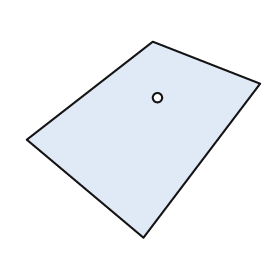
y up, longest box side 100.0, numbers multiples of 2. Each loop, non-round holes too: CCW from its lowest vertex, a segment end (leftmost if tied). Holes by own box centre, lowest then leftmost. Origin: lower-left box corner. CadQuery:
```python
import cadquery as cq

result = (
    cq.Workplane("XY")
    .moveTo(50.0, 0.0)
    .lineTo(100.0, 66.0)
    .lineTo(54.0, 84.0)
    .lineTo(0.0, 42.0)
    .close()
    .moveTo(56.0, 60.0)
    .circle(2.0)
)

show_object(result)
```